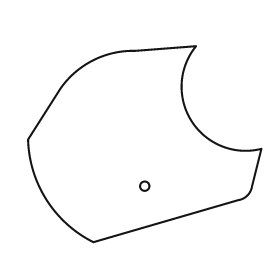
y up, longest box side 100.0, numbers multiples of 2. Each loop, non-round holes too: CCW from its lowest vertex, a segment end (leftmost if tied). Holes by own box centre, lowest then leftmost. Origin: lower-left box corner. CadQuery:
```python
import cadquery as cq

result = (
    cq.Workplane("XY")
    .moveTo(28.0, 0.0)
    .lineTo(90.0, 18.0)
    .threePointArc((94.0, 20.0), (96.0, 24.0))
    .lineTo(100.0, 40.0)
    .threePointArc((70.0, 52.0), (72.0, 84.0))
    .lineTo(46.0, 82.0)
    .threePointArc((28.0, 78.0), (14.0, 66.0))
    .lineTo(0.0, 44.0)
    .threePointArc((8.0, 18.0), (28.0, 0.0))
    .close()
    .moveTo(50.0, 24.0)
    .circle(2.0)
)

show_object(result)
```